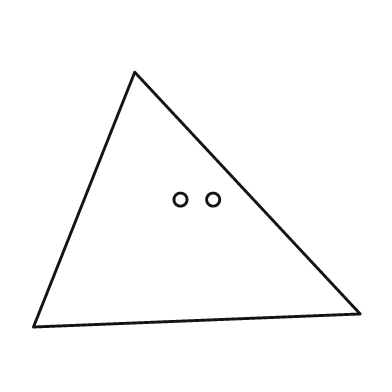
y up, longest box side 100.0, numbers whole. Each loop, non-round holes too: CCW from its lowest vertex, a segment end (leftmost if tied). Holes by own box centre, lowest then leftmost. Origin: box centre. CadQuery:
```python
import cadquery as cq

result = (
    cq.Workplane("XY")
    .moveTo(-50.0, -39.0)
    .lineTo(50.0, -35.0)
    .lineTo(-19.0, 39.0)
    .close()
    .moveTo(-5.0, 0.0)
    .circle(2.0)
    .moveTo(5.0, 0.0)
    .circle(2.0)
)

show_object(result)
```